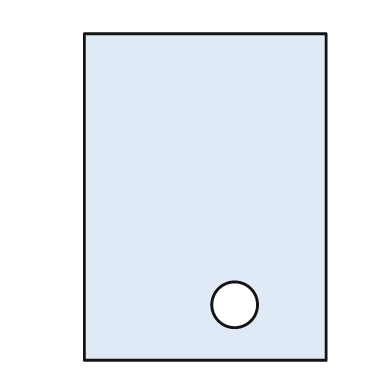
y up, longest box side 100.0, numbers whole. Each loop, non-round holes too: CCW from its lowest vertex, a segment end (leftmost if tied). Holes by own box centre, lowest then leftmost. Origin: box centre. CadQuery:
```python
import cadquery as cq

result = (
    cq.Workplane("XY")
    .moveTo(-37.0, -50.0)
    .lineTo(37.0, -50.0)
    .lineTo(37.0, 50.0)
    .lineTo(-37.0, 50.0)
    .close()
    .moveTo(9.0, -33.0)
    .circle(7.0)
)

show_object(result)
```